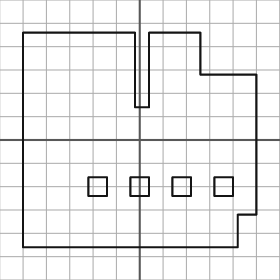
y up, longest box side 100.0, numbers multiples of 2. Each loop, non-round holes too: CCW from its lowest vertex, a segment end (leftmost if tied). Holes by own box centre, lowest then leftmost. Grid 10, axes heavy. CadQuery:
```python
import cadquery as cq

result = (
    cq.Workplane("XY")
    .moveTo(-50.0, -46.0)
    .lineTo(42.0, -46.0)
    .lineTo(42.0, -32.0)
    .lineTo(50.0, -32.0)
    .lineTo(50.0, 28.0)
    .lineTo(26.0, 28.0)
    .lineTo(26.0, 46.0)
    .lineTo(4.0, 46.0)
    .lineTo(4.0, 14.0)
    .lineTo(-2.0, 14.0)
    .lineTo(-2.0, 46.0)
    .lineTo(-50.0, 46.0)
    .close()
    .moveTo(-22.0, -24.0)
    .lineTo(-14.0, -24.0)
    .lineTo(-14.0, -16.0)
    .lineTo(-22.0, -16.0)
    .close()
    .moveTo(-4.0, -24.0)
    .lineTo(4.0, -24.0)
    .lineTo(4.0, -16.0)
    .lineTo(-4.0, -16.0)
    .close()
    .moveTo(14.0, -24.0)
    .lineTo(22.0, -24.0)
    .lineTo(22.0, -16.0)
    .lineTo(14.0, -16.0)
    .close()
    .moveTo(32.0, -24.0)
    .lineTo(40.0, -24.0)
    .lineTo(40.0, -16.0)
    .lineTo(32.0, -16.0)
    .close()
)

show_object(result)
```